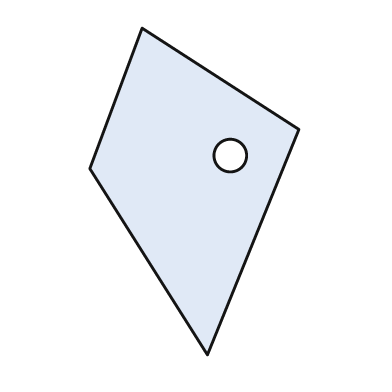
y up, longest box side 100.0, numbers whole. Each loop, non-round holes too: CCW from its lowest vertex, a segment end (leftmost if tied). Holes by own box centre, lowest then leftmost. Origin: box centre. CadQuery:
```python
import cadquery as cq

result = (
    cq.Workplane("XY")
    .moveTo(4.0, -50.0)
    .lineTo(32.0, 19.0)
    .lineTo(-16.0, 50.0)
    .lineTo(-32.0, 7.0)
    .close()
    .moveTo(11.0, 11.0)
    .circle(5.0)
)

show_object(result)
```